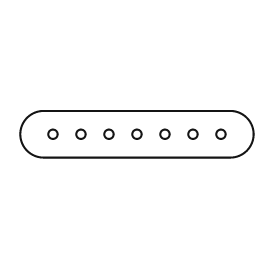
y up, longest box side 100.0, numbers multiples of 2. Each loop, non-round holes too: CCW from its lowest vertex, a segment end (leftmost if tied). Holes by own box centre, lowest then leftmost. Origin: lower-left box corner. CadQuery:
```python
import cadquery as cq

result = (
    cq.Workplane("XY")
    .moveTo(10.0, 0.0)
    .lineTo(90.0, 0.0)
    .threePointArc((100.0, 10.0), (90.0, 20.0))
    .lineTo(10.0, 20.0)
    .threePointArc((0.0, 10.0), (10.0, 0.0))
    .close()
    .moveTo(14.0, 10.0)
    .circle(2.0)
    .moveTo(26.0, 10.0)
    .circle(2.0)
    .moveTo(38.0, 10.0)
    .circle(2.0)
    .moveTo(50.0, 10.0)
    .circle(2.0)
    .moveTo(62.0, 10.0)
    .circle(2.0)
    .moveTo(74.0, 10.0)
    .circle(2.0)
    .moveTo(86.0, 10.0)
    .circle(2.0)
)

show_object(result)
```